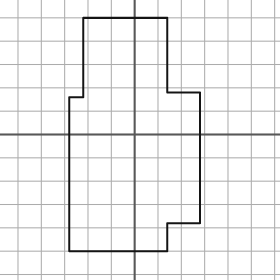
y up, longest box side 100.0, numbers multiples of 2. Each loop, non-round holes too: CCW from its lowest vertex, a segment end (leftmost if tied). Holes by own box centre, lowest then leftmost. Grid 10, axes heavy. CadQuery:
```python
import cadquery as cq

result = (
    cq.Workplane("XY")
    .moveTo(-28.0, -50.0)
    .lineTo(14.0, -50.0)
    .lineTo(14.0, -38.0)
    .lineTo(28.0, -38.0)
    .lineTo(28.0, 18.0)
    .lineTo(14.0, 18.0)
    .lineTo(14.0, 50.0)
    .lineTo(-22.0, 50.0)
    .lineTo(-22.0, 16.0)
    .lineTo(-28.0, 16.0)
    .close()
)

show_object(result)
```